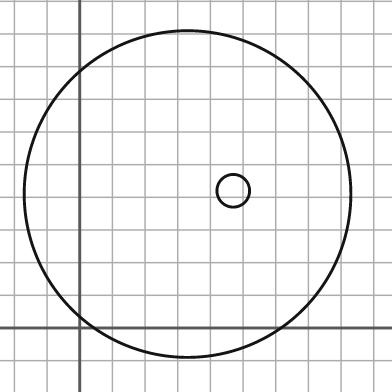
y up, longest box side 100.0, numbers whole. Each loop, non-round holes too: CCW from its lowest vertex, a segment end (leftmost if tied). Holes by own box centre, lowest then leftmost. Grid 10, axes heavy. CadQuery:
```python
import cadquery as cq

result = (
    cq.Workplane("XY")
    .moveTo(33.0, 41.0)
    .circle(50.0)
    .moveTo(47.0, 42.0)
    .circle(5.0)
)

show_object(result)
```